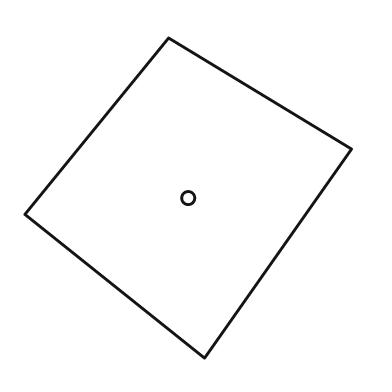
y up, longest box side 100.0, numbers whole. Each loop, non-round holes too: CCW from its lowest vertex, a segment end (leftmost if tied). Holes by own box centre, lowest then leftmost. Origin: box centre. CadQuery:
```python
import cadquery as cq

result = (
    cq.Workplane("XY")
    .moveTo(5.0, -49.0)
    .lineTo(50.0, 15.0)
    .lineTo(-6.0, 49.0)
    .lineTo(-50.0, -5.0)
    .close()
    .moveTo(0.0, 0.0)
    .circle(2.0)
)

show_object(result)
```